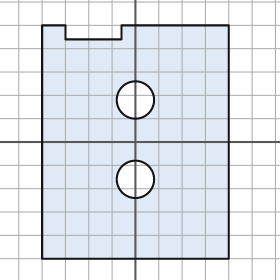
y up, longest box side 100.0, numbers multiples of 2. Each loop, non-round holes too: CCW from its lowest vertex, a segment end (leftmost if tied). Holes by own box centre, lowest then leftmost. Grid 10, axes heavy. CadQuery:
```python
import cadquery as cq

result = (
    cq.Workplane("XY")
    .moveTo(-40.0, -50.0)
    .lineTo(40.0, -50.0)
    .lineTo(40.0, 50.0)
    .lineTo(-6.0, 50.0)
    .lineTo(-6.0, 44.0)
    .lineTo(-30.0, 44.0)
    .lineTo(-30.0, 50.0)
    .lineTo(-40.0, 50.0)
    .close()
    .moveTo(0.0, -16.0)
    .circle(8.0)
    .moveTo(0.0, 18.0)
    .circle(8.0)
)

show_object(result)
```